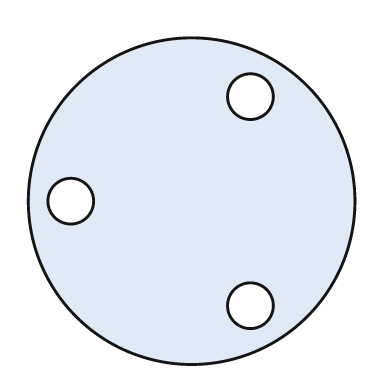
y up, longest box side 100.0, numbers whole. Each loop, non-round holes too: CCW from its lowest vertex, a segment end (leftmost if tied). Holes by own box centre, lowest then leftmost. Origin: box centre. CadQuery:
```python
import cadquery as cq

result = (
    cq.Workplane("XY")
    .moveTo(0.0, 0.0)
    .circle(50.0)
    .moveTo(18.0, -32.0)
    .circle(7.0)
    .moveTo(-37.0, 0.0)
    .circle(7.0)
    .moveTo(18.0, 32.0)
    .circle(7.0)
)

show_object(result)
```